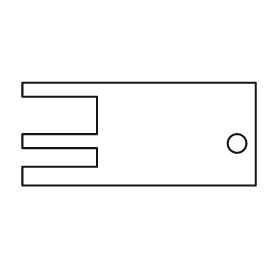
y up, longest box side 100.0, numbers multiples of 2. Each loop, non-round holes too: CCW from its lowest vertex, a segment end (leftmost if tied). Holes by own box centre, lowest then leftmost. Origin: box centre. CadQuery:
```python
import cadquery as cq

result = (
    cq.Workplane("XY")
    .moveTo(-50.0, -22.0)
    .lineTo(50.0, -22.0)
    .lineTo(50.0, 22.0)
    .lineTo(-50.0, 22.0)
    .lineTo(-50.0, 16.0)
    .lineTo(-18.0, 16.0)
    .lineTo(-18.0, 0.0)
    .lineTo(-50.0, 0.0)
    .lineTo(-50.0, -6.0)
    .lineTo(-18.0, -6.0)
    .lineTo(-18.0, -14.0)
    .lineTo(-50.0, -14.0)
    .close()
    .moveTo(42.0, -4.0)
    .circle(4.0)
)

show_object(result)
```